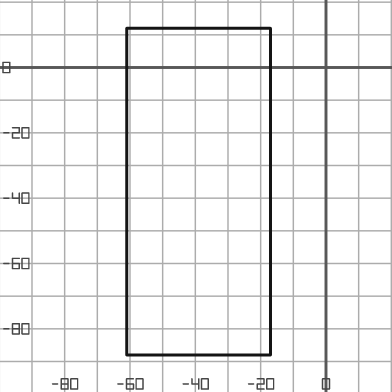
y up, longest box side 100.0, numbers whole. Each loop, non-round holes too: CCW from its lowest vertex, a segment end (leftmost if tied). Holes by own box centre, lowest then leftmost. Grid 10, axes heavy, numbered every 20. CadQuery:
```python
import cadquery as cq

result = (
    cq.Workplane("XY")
    .moveTo(-61.0, -88.0)
    .lineTo(-17.0, -88.0)
    .lineTo(-17.0, 12.0)
    .lineTo(-61.0, 12.0)
    .close()
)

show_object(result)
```